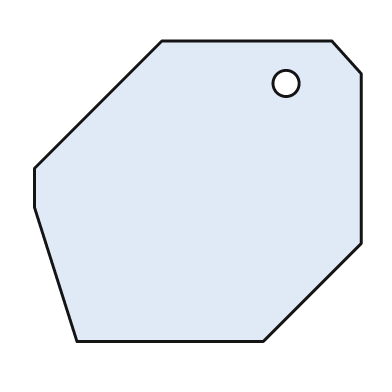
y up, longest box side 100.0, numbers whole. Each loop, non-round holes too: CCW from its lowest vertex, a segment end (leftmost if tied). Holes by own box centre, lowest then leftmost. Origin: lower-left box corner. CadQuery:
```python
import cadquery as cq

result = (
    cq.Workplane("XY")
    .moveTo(13.0, 0.0)
    .lineTo(70.0, 0.0)
    .lineTo(100.0, 30.0)
    .lineTo(100.0, 82.0)
    .lineTo(91.0, 92.0)
    .lineTo(39.0, 92.0)
    .lineTo(0.0, 53.0)
    .lineTo(0.0, 41.0)
    .close()
    .moveTo(77.0, 79.0)
    .circle(4.0)
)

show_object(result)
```